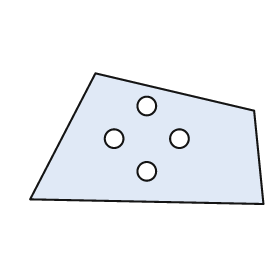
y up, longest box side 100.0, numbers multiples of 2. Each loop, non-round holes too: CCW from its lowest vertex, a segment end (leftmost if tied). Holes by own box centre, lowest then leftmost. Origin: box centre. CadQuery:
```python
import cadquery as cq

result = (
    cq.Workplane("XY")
    .moveTo(50.0, -28.0)
    .lineTo(46.0, 12.0)
    .lineTo(-22.0, 28.0)
    .lineTo(-50.0, -26.0)
    .close()
    .moveTo(0.0, -14.0)
    .circle(4.0)
    .moveTo(-14.0, 0.0)
    .circle(4.0)
    .moveTo(14.0, 0.0)
    .circle(4.0)
    .moveTo(0.0, 14.0)
    .circle(4.0)
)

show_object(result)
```